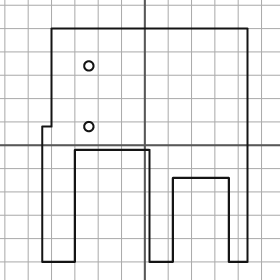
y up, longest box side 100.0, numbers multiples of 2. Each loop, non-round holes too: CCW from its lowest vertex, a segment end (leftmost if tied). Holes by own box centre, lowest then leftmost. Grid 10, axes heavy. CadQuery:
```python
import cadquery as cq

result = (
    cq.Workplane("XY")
    .moveTo(-44.0, -50.0)
    .lineTo(-30.0, -50.0)
    .lineTo(-30.0, -2.0)
    .lineTo(2.0, -2.0)
    .lineTo(2.0, -50.0)
    .lineTo(12.0, -50.0)
    .lineTo(12.0, -14.0)
    .lineTo(36.0, -14.0)
    .lineTo(36.0, -50.0)
    .lineTo(44.0, -50.0)
    .lineTo(44.0, 50.0)
    .lineTo(-40.0, 50.0)
    .lineTo(-40.0, 8.0)
    .lineTo(-44.0, 8.0)
    .close()
    .moveTo(-24.0, 8.0)
    .circle(2.0)
    .moveTo(-24.0, 34.0)
    .circle(2.0)
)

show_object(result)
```